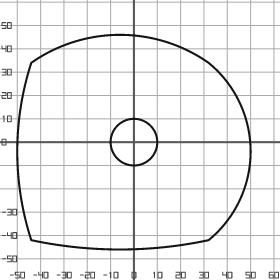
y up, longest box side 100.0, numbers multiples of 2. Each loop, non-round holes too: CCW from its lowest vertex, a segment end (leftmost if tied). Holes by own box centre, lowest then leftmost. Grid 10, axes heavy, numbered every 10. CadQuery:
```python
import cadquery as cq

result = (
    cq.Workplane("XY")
    .moveTo(-44.0, -42.0)
    .threePointArc((-6.0, -46.0), (32.0, -42.0))
    .threePointArc((50.0, -4.0), (32.0, 34.0))
    .threePointArc((-6.0, 46.0), (-44.0, 34.0))
    .threePointArc((-50.0, -4.0), (-44.0, -42.0))
    .close()
    .moveTo(0.0, 0.0)
    .circle(10.0)
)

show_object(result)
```